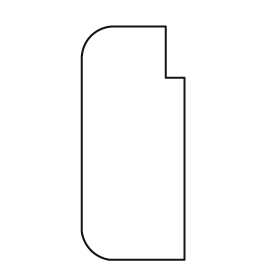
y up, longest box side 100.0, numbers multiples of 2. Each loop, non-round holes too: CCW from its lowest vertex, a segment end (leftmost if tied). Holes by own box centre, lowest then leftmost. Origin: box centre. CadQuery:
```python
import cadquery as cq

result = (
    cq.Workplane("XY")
    .moveTo(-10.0, -50.0)
    .lineTo(22.0, -50.0)
    .lineTo(22.0, 28.0)
    .lineTo(14.0, 28.0)
    .lineTo(14.0, 50.0)
    .lineTo(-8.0, 50.0)
    .threePointArc((-18.0, 46.0), (-22.0, 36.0))
    .lineTo(-22.0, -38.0)
    .threePointArc((-18.0, -46.0), (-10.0, -50.0))
    .close()
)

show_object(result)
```